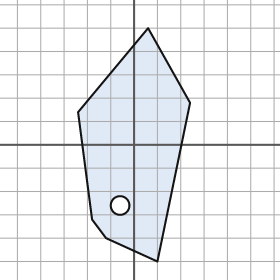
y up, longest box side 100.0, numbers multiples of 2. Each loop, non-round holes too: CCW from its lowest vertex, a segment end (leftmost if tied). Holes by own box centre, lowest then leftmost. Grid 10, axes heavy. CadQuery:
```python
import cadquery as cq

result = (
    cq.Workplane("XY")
    .moveTo(10.0, -50.0)
    .lineTo(24.0, 18.0)
    .lineTo(6.0, 50.0)
    .lineTo(-24.0, 14.0)
    .lineTo(-18.0, -32.0)
    .lineTo(-12.0, -40.0)
    .close()
    .moveTo(-6.0, -26.0)
    .circle(4.0)
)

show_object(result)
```